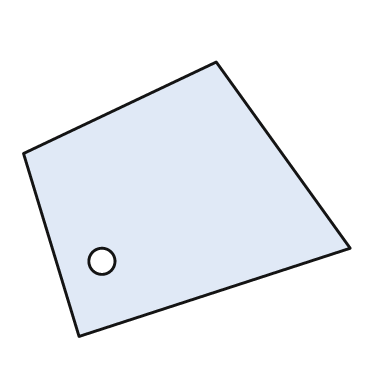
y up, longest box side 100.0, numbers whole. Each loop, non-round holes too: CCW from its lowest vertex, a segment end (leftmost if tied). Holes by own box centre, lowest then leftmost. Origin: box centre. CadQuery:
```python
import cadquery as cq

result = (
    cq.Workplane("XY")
    .moveTo(-33.0, -42.0)
    .lineTo(50.0, -15.0)
    .lineTo(9.0, 42.0)
    .lineTo(-50.0, 14.0)
    .close()
    .moveTo(-26.0, -19.0)
    .circle(4.0)
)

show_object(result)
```